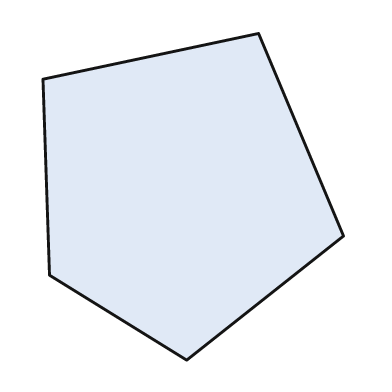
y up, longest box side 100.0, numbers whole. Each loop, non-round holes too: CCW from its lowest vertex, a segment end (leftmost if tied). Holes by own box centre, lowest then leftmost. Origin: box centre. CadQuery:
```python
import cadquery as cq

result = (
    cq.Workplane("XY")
    .moveTo(-2.0, -50.0)
    .lineTo(46.0, -12.0)
    .lineTo(20.0, 50.0)
    .lineTo(-46.0, 36.0)
    .lineTo(-44.0, -24.0)
    .close()
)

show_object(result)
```